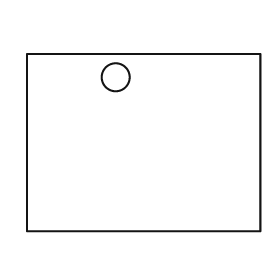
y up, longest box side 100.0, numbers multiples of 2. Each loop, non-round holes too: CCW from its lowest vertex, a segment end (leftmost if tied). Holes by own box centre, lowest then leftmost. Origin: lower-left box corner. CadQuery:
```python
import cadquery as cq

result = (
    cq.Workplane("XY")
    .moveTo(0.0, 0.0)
    .lineTo(100.0, 0.0)
    .lineTo(100.0, 76.0)
    .lineTo(0.0, 76.0)
    .close()
    .moveTo(38.0, 66.0)
    .circle(6.0)
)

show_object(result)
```